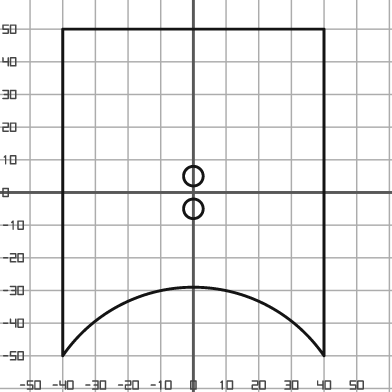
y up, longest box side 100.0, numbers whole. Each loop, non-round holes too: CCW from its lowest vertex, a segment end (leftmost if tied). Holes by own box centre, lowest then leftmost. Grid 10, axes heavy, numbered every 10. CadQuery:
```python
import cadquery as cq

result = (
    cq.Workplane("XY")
    .moveTo(-40.0, -50.0)
    .threePointArc((0.0, -29.0), (40.0, -50.0))
    .lineTo(40.0, 50.0)
    .lineTo(-40.0, 50.0)
    .close()
    .moveTo(0.0, -5.0)
    .circle(3.0)
    .moveTo(0.0, 5.0)
    .circle(3.0)
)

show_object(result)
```